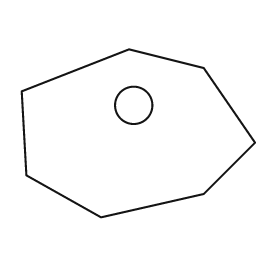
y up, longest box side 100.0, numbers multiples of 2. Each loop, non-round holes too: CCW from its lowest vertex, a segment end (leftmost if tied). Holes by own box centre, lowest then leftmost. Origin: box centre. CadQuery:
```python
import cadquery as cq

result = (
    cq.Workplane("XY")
    .moveTo(-16.0, -36.0)
    .lineTo(28.0, -26.0)
    .lineTo(50.0, -4.0)
    .lineTo(28.0, 28.0)
    .lineTo(-4.0, 36.0)
    .lineTo(-50.0, 18.0)
    .lineTo(-48.0, -18.0)
    .close()
    .moveTo(-2.0, 12.0)
    .circle(8.0)
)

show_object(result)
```